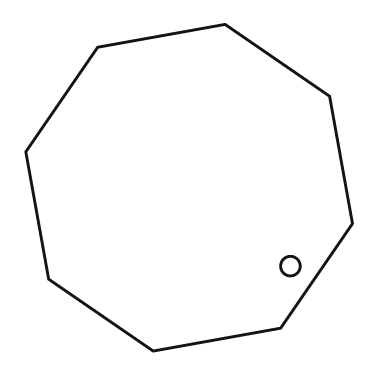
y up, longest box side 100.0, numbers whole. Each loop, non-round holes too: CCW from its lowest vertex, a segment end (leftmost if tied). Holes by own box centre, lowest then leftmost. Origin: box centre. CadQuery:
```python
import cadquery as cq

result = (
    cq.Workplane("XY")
    .moveTo(-11.0, -50.0)
    .lineTo(28.0, -43.0)
    .lineTo(50.0, -11.0)
    .lineTo(43.0, 28.0)
    .lineTo(11.0, 50.0)
    .lineTo(-28.0, 43.0)
    .lineTo(-50.0, 11.0)
    .lineTo(-43.0, -28.0)
    .close()
    .moveTo(31.0, -24.0)
    .circle(3.0)
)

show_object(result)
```